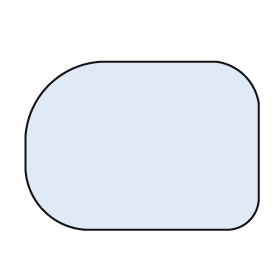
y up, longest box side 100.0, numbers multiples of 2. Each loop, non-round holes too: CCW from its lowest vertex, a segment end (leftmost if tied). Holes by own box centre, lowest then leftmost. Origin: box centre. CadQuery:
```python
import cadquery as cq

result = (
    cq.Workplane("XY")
    .moveTo(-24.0, -36.0)
    .lineTo(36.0, -36.0)
    .threePointArc((46.0, -32.0), (50.0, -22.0))
    .lineTo(50.0, 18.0)
    .threePointArc((44.0, 30.0), (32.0, 36.0))
    .lineTo(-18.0, 36.0)
    .threePointArc((-40.0, 26.0), (-50.0, 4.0))
    .lineTo(-50.0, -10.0)
    .threePointArc((-42.0, -28.0), (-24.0, -36.0))
    .close()
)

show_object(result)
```